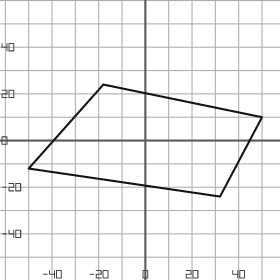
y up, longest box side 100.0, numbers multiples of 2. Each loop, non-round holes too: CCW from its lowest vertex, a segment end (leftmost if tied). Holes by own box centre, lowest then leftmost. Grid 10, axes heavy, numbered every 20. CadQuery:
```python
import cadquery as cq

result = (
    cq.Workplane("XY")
    .moveTo(32.0, -24.0)
    .lineTo(50.0, 10.0)
    .lineTo(-18.0, 24.0)
    .lineTo(-50.0, -12.0)
    .close()
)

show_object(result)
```